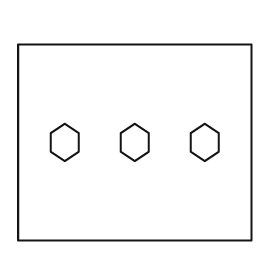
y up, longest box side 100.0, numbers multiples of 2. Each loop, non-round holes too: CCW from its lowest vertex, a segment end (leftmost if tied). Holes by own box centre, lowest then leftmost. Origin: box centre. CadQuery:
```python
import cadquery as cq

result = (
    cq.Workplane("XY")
    .moveTo(-50.0, -42.0)
    .lineTo(50.0, -42.0)
    .lineTo(50.0, 42.0)
    .lineTo(-50.0, 42.0)
    .close()
    .moveTo(-30.0, -8.0)
    .lineTo(-24.0, -4.0)
    .lineTo(-24.0, 4.0)
    .lineTo(-30.0, 8.0)
    .lineTo(-36.0, 4.0)
    .lineTo(-36.0, -4.0)
    .close()
    .moveTo(0.0, -8.0)
    .lineTo(6.0, -4.0)
    .lineTo(6.0, 4.0)
    .lineTo(0.0, 8.0)
    .lineTo(-6.0, 4.0)
    .lineTo(-6.0, -4.0)
    .close()
    .moveTo(30.0, -8.0)
    .lineTo(36.0, -4.0)
    .lineTo(36.0, 4.0)
    .lineTo(30.0, 8.0)
    .lineTo(24.0, 4.0)
    .lineTo(24.0, -4.0)
    .close()
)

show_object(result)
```